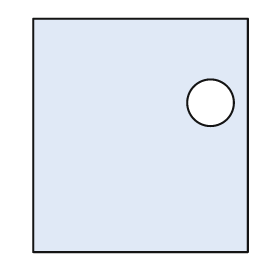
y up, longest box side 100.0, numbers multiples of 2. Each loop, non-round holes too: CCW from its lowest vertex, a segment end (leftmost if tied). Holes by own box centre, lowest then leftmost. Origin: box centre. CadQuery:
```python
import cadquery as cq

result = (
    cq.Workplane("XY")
    .moveTo(-46.0, -50.0)
    .lineTo(46.0, -50.0)
    .lineTo(46.0, 50.0)
    .lineTo(-46.0, 50.0)
    .close()
    .moveTo(30.0, 14.0)
    .circle(10.0)
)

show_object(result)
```